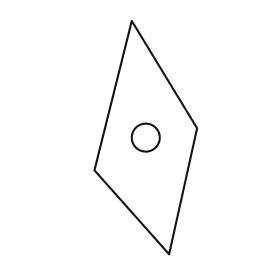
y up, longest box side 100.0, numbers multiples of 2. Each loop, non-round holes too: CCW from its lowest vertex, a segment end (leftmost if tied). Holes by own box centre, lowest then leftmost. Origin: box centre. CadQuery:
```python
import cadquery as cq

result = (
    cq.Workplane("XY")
    .moveTo(10.0, -50.0)
    .lineTo(22.0, 4.0)
    .lineTo(-6.0, 50.0)
    .lineTo(-22.0, -14.0)
    .close()
    .moveTo(0.0, 0.0)
    .circle(6.0)
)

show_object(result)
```